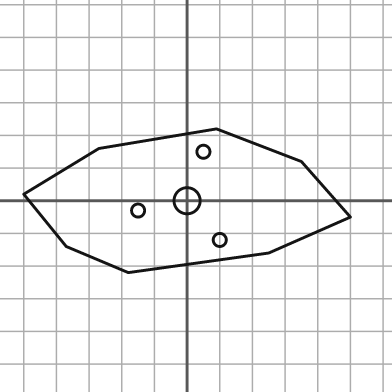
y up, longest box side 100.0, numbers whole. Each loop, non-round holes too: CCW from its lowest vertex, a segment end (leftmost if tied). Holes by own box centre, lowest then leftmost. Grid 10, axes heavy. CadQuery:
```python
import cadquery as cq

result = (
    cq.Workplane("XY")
    .moveTo(-18.0, -22.0)
    .lineTo(25.0, -16.0)
    .lineTo(50.0, -5.0)
    .lineTo(35.0, 12.0)
    .lineTo(9.0, 22.0)
    .lineTo(-27.0, 16.0)
    .lineTo(-50.0, 2.0)
    .lineTo(-37.0, -14.0)
    .close()
    .moveTo(10.0, -12.0)
    .circle(2.0)
    .moveTo(-15.0, -3.0)
    .circle(2.0)
    .moveTo(0.0, 0.0)
    .circle(4.0)
    .moveTo(5.0, 15.0)
    .circle(2.0)
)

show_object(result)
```